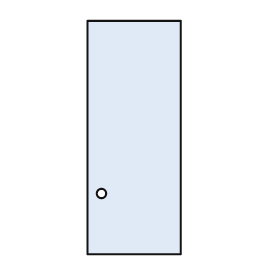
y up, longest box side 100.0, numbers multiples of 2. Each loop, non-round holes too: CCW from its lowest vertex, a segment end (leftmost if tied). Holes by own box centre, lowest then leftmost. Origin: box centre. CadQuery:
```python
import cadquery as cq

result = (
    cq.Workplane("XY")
    .moveTo(-20.0, -50.0)
    .lineTo(20.0, -50.0)
    .lineTo(20.0, 50.0)
    .lineTo(-20.0, 50.0)
    .close()
    .moveTo(-14.0, -24.0)
    .circle(2.0)
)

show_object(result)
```